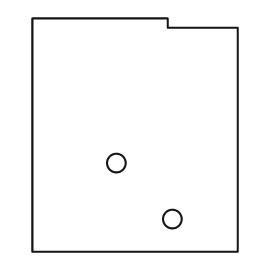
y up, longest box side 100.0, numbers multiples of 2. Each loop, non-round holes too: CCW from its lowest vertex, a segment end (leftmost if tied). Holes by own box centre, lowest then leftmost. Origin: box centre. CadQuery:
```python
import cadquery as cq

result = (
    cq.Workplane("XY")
    .moveTo(-44.0, -50.0)
    .lineTo(44.0, -50.0)
    .lineTo(44.0, 46.0)
    .lineTo(14.0, 46.0)
    .lineTo(14.0, 50.0)
    .lineTo(-44.0, 50.0)
    .close()
    .moveTo(16.0, -36.0)
    .circle(4.0)
    .moveTo(-8.0, -12.0)
    .circle(4.0)
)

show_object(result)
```